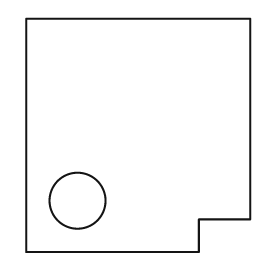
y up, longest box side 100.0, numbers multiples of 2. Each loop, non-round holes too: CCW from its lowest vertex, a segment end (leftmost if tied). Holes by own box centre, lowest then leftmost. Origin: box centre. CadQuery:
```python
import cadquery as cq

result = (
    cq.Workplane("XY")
    .moveTo(-48.0, -50.0)
    .lineTo(26.0, -50.0)
    .lineTo(26.0, -36.0)
    .lineTo(48.0, -36.0)
    .lineTo(48.0, 50.0)
    .lineTo(-48.0, 50.0)
    .close()
    .moveTo(-26.0, -28.0)
    .circle(12.0)
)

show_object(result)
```